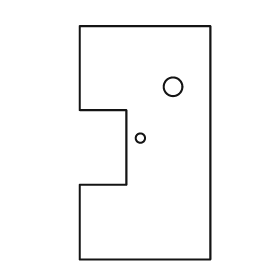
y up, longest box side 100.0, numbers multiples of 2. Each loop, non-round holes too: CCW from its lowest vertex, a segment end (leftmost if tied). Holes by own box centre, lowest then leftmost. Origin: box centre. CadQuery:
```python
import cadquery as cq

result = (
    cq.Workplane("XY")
    .moveTo(-28.0, -50.0)
    .lineTo(28.0, -50.0)
    .lineTo(28.0, 50.0)
    .lineTo(-28.0, 50.0)
    .lineTo(-28.0, 14.0)
    .lineTo(-8.0, 14.0)
    .lineTo(-8.0, -18.0)
    .lineTo(-28.0, -18.0)
    .close()
    .moveTo(-2.0, 2.0)
    .circle(2.0)
    .moveTo(12.0, 24.0)
    .circle(4.0)
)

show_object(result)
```